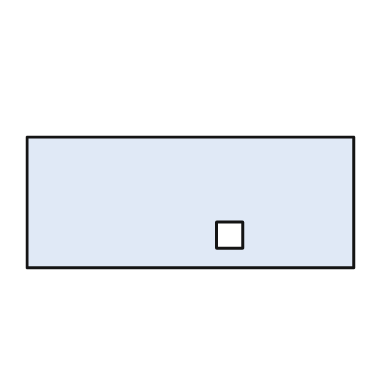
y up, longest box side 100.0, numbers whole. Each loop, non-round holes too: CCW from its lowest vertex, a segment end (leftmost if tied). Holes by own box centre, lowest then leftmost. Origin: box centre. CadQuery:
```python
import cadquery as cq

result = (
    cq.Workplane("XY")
    .moveTo(-50.0, -20.0)
    .lineTo(50.0, -20.0)
    .lineTo(50.0, 20.0)
    .lineTo(-50.0, 20.0)
    .close()
    .moveTo(8.0, -14.0)
    .lineTo(16.0, -14.0)
    .lineTo(16.0, -6.0)
    .lineTo(8.0, -6.0)
    .close()
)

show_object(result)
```